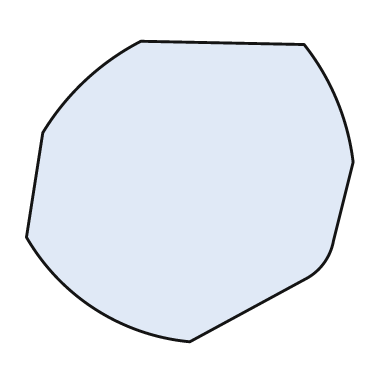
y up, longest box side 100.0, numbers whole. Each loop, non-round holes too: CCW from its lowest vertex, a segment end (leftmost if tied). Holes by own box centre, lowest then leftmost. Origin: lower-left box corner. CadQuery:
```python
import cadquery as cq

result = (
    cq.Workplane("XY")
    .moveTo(50.0, 0.0)
    .lineTo(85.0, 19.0)
    .threePointArc((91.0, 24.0), (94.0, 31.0))
    .lineTo(100.0, 55.0)
    .threePointArc((95.0, 74.0), (85.0, 91.0))
    .lineTo(35.0, 92.0)
    .threePointArc((18.0, 80.0), (5.0, 64.0))
    .lineTo(0.0, 32.0)
    .threePointArc((21.0, 10.0), (50.0, 0.0))
    .close()
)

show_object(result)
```